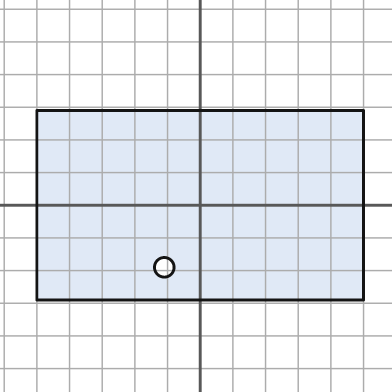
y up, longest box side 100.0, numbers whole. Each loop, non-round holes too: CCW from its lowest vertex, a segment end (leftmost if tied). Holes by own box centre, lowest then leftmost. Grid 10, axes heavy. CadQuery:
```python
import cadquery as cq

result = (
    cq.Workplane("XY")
    .moveTo(-50.0, -29.0)
    .lineTo(50.0, -29.0)
    .lineTo(50.0, 29.0)
    .lineTo(-50.0, 29.0)
    .close()
    .moveTo(-11.0, -19.0)
    .circle(3.0)
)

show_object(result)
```